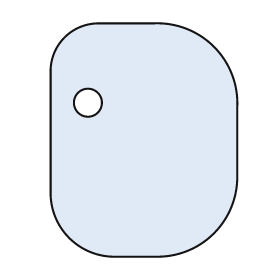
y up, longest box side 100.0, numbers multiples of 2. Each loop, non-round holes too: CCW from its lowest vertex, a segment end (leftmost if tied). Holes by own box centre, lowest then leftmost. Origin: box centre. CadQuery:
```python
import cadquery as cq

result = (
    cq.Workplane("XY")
    .moveTo(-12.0, -50.0)
    .lineTo(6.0, -50.0)
    .threePointArc((30.0, -40.0), (40.0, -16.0))
    .lineTo(40.0, 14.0)
    .threePointArc((30.0, 40.0), (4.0, 50.0))
    .lineTo(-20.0, 50.0)
    .threePointArc((-34.0, 44.0), (-40.0, 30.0))
    .lineTo(-40.0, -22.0)
    .threePointArc((-32.0, -42.0), (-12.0, -50.0))
    .close()
    .moveTo(-24.0, 16.0)
    .circle(6.0)
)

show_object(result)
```